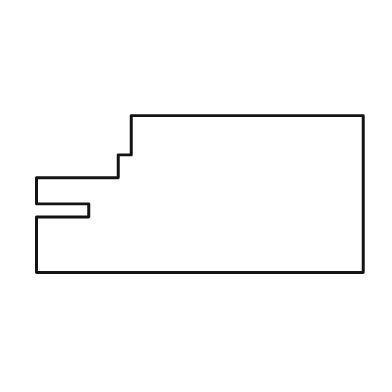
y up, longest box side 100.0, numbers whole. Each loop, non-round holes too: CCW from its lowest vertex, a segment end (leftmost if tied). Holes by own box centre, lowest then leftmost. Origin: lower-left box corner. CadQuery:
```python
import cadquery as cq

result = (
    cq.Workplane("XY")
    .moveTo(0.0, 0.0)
    .lineTo(100.0, 0.0)
    .lineTo(100.0, 48.0)
    .lineTo(29.0, 48.0)
    .lineTo(29.0, 36.0)
    .lineTo(25.0, 36.0)
    .lineTo(25.0, 29.0)
    .lineTo(0.0, 29.0)
    .lineTo(0.0, 21.0)
    .lineTo(16.0, 21.0)
    .lineTo(16.0, 17.0)
    .lineTo(0.0, 17.0)
    .close()
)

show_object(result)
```